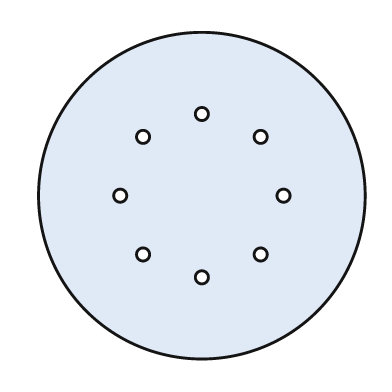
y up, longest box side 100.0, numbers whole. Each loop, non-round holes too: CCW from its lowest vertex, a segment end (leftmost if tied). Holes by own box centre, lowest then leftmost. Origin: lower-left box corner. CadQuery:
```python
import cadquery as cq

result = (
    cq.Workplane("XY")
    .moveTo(50.0, 50.0)
    .circle(50.0)
    .moveTo(50.0, 25.0)
    .circle(2.0)
    .moveTo(32.0, 32.0)
    .circle(2.0)
    .moveTo(68.0, 32.0)
    .circle(2.0)
    .moveTo(25.0, 50.0)
    .circle(2.0)
    .moveTo(75.0, 50.0)
    .circle(2.0)
    .moveTo(32.0, 68.0)
    .circle(2.0)
    .moveTo(68.0, 68.0)
    .circle(2.0)
    .moveTo(50.0, 75.0)
    .circle(2.0)
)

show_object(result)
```